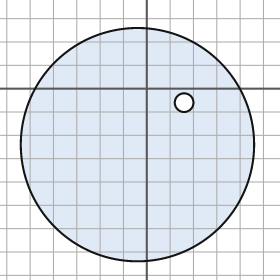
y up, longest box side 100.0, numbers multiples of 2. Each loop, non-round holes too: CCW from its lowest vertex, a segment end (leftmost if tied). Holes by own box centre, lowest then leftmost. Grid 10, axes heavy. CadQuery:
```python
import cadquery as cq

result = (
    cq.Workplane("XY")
    .moveTo(-4.0, -24.0)
    .circle(50.0)
    .moveTo(16.0, -6.0)
    .circle(4.0)
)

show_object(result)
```